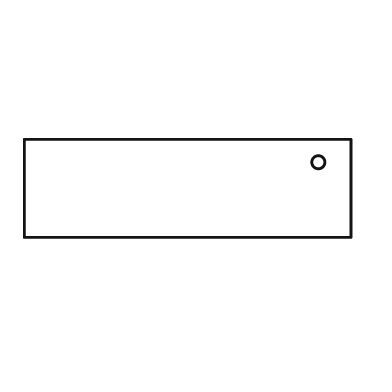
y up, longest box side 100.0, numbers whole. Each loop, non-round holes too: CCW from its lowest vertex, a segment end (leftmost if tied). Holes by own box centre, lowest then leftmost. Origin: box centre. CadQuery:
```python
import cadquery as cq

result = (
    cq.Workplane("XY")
    .moveTo(-50.0, -15.0)
    .lineTo(50.0, -15.0)
    .lineTo(50.0, 15.0)
    .lineTo(-50.0, 15.0)
    .close()
    .moveTo(40.0, 8.0)
    .circle(2.0)
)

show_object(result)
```